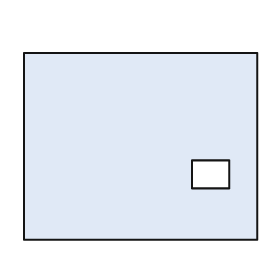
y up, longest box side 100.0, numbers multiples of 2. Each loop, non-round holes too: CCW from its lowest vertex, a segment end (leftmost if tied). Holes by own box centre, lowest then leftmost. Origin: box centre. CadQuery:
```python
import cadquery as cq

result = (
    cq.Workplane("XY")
    .moveTo(-50.0, -40.0)
    .lineTo(50.0, -40.0)
    .lineTo(50.0, 40.0)
    .lineTo(-50.0, 40.0)
    .close()
    .moveTo(22.0, -18.0)
    .lineTo(38.0, -18.0)
    .lineTo(38.0, -6.0)
    .lineTo(22.0, -6.0)
    .close()
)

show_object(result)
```